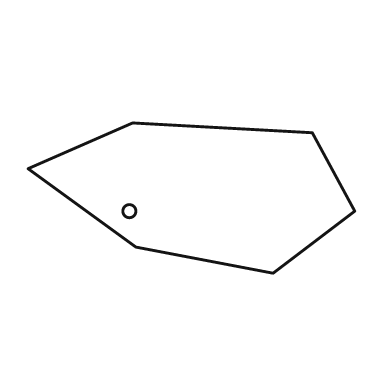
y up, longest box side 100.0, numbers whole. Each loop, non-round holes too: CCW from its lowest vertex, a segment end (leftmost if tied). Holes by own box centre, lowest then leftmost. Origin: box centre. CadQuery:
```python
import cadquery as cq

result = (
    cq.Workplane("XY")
    .moveTo(25.0, -23.0)
    .lineTo(50.0, -4.0)
    .lineTo(37.0, 20.0)
    .lineTo(-18.0, 23.0)
    .lineTo(-50.0, 9.0)
    .lineTo(-17.0, -15.0)
    .close()
    .moveTo(-19.0, -4.0)
    .circle(2.0)
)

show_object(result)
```